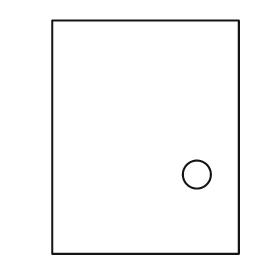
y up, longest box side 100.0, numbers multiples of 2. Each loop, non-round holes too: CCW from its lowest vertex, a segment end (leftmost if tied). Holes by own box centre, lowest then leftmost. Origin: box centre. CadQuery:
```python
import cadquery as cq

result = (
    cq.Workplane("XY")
    .moveTo(-40.0, -50.0)
    .lineTo(40.0, -50.0)
    .lineTo(40.0, 50.0)
    .lineTo(-40.0, 50.0)
    .close()
    .moveTo(22.0, -16.0)
    .circle(6.0)
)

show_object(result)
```